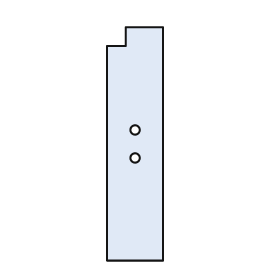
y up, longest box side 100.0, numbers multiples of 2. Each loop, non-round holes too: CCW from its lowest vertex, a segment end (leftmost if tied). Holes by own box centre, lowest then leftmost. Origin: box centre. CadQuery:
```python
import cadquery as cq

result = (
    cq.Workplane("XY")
    .moveTo(-12.0, -50.0)
    .lineTo(12.0, -50.0)
    .lineTo(12.0, 50.0)
    .lineTo(-4.0, 50.0)
    .lineTo(-4.0, 42.0)
    .lineTo(-12.0, 42.0)
    .close()
    .moveTo(0.0, -6.0)
    .circle(2.0)
    .moveTo(0.0, 6.0)
    .circle(2.0)
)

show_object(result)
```